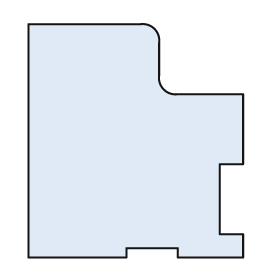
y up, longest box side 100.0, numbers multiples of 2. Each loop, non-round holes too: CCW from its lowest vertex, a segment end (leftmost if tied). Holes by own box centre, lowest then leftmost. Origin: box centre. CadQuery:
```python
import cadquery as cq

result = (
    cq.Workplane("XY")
    .moveTo(-46.0, -50.0)
    .lineTo(-4.0, -50.0)
    .lineTo(-4.0, -46.0)
    .lineTo(18.0, -46.0)
    .lineTo(18.0, -50.0)
    .lineTo(46.0, -50.0)
    .lineTo(46.0, -40.0)
    .lineTo(36.0, -40.0)
    .lineTo(36.0, -10.0)
    .lineTo(46.0, -10.0)
    .lineTo(46.0, 20.0)
    .lineTo(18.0, 20.0)
    .threePointArc((12.0, 22.0), (10.0, 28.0))
    .lineTo(10.0, 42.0)
    .threePointArc((8.0, 48.0), (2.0, 50.0))
    .lineTo(-46.0, 50.0)
    .close()
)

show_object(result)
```